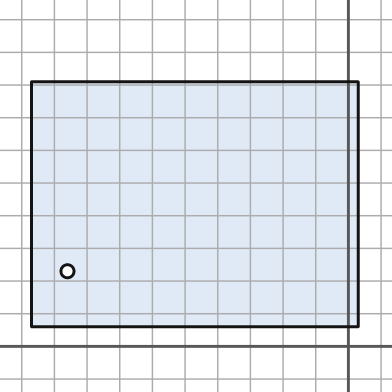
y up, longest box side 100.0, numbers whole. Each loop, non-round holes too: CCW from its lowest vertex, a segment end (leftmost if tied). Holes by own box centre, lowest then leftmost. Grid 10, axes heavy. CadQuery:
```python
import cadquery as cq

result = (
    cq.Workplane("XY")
    .moveTo(-97.0, 6.0)
    .lineTo(3.0, 6.0)
    .lineTo(3.0, 81.0)
    .lineTo(-97.0, 81.0)
    .close()
    .moveTo(-86.0, 23.0)
    .circle(2.0)
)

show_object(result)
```